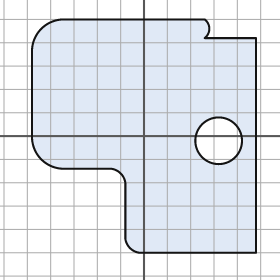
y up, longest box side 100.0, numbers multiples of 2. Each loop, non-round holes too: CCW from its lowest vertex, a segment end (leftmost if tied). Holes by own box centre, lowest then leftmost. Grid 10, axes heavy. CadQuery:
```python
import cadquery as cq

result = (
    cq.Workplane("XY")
    .moveTo(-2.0, -50.0)
    .lineTo(48.0, -50.0)
    .lineTo(48.0, 42.0)
    .lineTo(26.0, 42.0)
    .threePointArc((28.0, 46.0), (26.0, 50.0))
    .lineTo(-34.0, 50.0)
    .threePointArc((-44.0, 46.0), (-48.0, 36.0))
    .lineTo(-48.0, 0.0)
    .threePointArc((-44.0, -10.0), (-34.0, -14.0))
    .lineTo(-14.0, -14.0)
    .threePointArc((-10.0, -16.0), (-8.0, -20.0))
    .lineTo(-8.0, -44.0)
    .threePointArc((-6.0, -48.0), (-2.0, -50.0))
    .close()
    .moveTo(32.0, -2.0)
    .circle(10.0)
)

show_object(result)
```